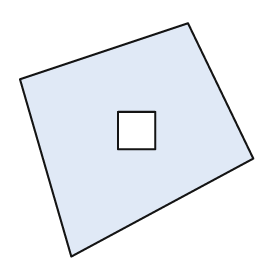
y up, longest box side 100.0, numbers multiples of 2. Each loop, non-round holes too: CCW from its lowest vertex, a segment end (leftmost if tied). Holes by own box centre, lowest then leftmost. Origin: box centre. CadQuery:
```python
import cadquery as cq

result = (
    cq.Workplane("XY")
    .moveTo(-28.0, -50.0)
    .lineTo(50.0, -8.0)
    .lineTo(22.0, 50.0)
    .lineTo(-50.0, 26.0)
    .close()
    .moveTo(-8.0, -4.0)
    .lineTo(8.0, -4.0)
    .lineTo(8.0, 12.0)
    .lineTo(-8.0, 12.0)
    .close()
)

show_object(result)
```